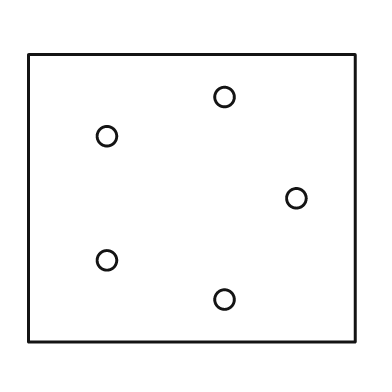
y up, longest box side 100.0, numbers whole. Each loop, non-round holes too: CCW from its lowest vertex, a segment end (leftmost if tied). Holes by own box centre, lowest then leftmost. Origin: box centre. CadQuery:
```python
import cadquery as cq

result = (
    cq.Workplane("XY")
    .moveTo(-50.0, -44.0)
    .lineTo(50.0, -44.0)
    .lineTo(50.0, 44.0)
    .lineTo(-50.0, 44.0)
    .close()
    .moveTo(10.0, -31.0)
    .circle(3.0)
    .moveTo(-26.0, -19.0)
    .circle(3.0)
    .moveTo(32.0, 0.0)
    .circle(3.0)
    .moveTo(-26.0, 19.0)
    .circle(3.0)
    .moveTo(10.0, 31.0)
    .circle(3.0)
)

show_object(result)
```